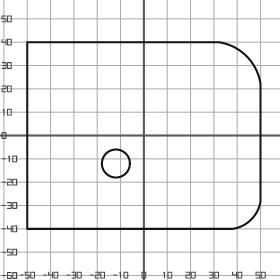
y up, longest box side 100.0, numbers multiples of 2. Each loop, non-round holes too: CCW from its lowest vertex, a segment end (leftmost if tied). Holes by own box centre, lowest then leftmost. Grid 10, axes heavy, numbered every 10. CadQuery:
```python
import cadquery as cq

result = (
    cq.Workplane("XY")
    .moveTo(-50.0, -40.0)
    .lineTo(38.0, -40.0)
    .threePointArc((46.0, -36.0), (50.0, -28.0))
    .lineTo(50.0, 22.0)
    .threePointArc((44.0, 34.0), (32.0, 40.0))
    .lineTo(-50.0, 40.0)
    .close()
    .moveTo(-12.0, -12.0)
    .circle(6.0)
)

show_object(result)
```